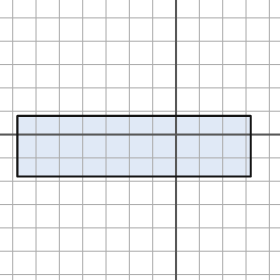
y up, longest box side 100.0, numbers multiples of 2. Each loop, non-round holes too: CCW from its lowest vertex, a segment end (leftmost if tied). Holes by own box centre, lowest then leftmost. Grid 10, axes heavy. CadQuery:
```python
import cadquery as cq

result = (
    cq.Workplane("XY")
    .moveTo(-68.0, -18.0)
    .lineTo(32.0, -18.0)
    .lineTo(32.0, 8.0)
    .lineTo(-68.0, 8.0)
    .close()
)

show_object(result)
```